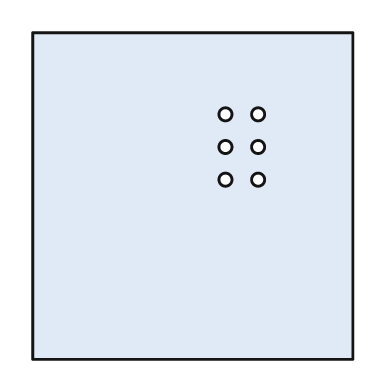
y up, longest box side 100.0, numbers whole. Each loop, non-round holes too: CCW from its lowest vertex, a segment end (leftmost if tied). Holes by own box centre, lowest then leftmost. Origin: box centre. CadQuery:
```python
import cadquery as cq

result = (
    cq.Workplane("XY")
    .moveTo(-49.0, -50.0)
    .lineTo(49.0, -50.0)
    .lineTo(49.0, 50.0)
    .lineTo(-49.0, 50.0)
    .close()
    .moveTo(10.0, 5.0)
    .circle(2.0)
    .moveTo(20.0, 5.0)
    .circle(2.0)
    .moveTo(10.0, 15.0)
    .circle(2.0)
    .moveTo(20.0, 15.0)
    .circle(2.0)
    .moveTo(10.0, 25.0)
    .circle(2.0)
    .moveTo(20.0, 25.0)
    .circle(2.0)
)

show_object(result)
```